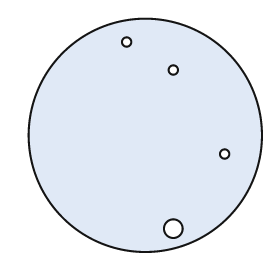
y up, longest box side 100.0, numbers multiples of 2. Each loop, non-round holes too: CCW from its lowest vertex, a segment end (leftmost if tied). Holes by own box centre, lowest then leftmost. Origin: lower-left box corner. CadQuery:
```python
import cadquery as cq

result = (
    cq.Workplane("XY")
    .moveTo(50.0, 50.0)
    .circle(50.0)
    .moveTo(62.0, 10.0)
    .circle(4.0)
    .moveTo(84.0, 42.0)
    .circle(2.0)
    .moveTo(62.0, 78.0)
    .circle(2.0)
    .moveTo(42.0, 90.0)
    .circle(2.0)
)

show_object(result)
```